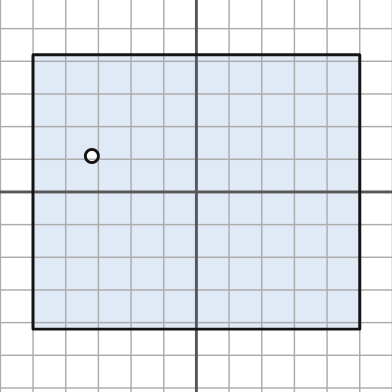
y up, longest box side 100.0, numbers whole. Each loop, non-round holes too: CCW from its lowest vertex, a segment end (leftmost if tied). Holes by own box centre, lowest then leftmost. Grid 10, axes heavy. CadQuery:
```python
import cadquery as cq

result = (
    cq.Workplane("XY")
    .moveTo(-50.0, -42.0)
    .lineTo(50.0, -42.0)
    .lineTo(50.0, 42.0)
    .lineTo(-50.0, 42.0)
    .close()
    .moveTo(-32.0, 11.0)
    .circle(2.0)
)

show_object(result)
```